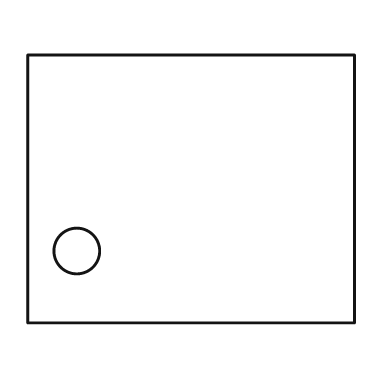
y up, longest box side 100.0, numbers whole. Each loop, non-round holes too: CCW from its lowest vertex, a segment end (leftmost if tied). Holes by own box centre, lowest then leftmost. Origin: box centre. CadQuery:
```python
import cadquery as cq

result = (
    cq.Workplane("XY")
    .moveTo(-50.0, -41.0)
    .lineTo(50.0, -41.0)
    .lineTo(50.0, 41.0)
    .lineTo(-50.0, 41.0)
    .close()
    .moveTo(-35.0, -19.0)
    .circle(7.0)
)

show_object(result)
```